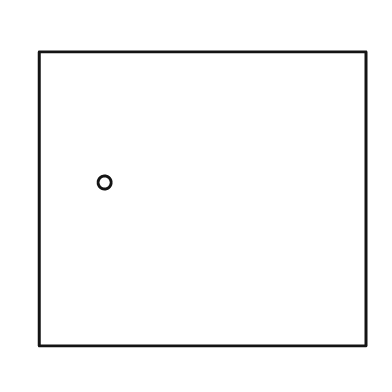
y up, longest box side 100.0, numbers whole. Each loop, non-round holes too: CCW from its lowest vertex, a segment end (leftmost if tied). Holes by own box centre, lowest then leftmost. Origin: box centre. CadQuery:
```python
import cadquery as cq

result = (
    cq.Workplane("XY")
    .moveTo(-50.0, -45.0)
    .lineTo(50.0, -45.0)
    .lineTo(50.0, 45.0)
    .lineTo(-50.0, 45.0)
    .close()
    .moveTo(-30.0, 5.0)
    .circle(2.0)
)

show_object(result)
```